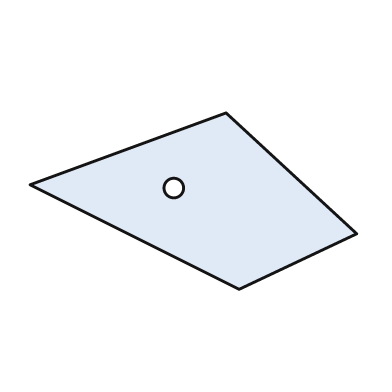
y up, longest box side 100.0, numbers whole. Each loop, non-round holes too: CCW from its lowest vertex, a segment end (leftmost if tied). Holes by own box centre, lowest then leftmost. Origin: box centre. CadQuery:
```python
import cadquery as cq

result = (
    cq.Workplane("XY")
    .moveTo(14.0, -27.0)
    .lineTo(50.0, -10.0)
    .lineTo(10.0, 27.0)
    .lineTo(-50.0, 5.0)
    .close()
    .moveTo(-6.0, 4.0)
    .circle(3.0)
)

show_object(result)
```